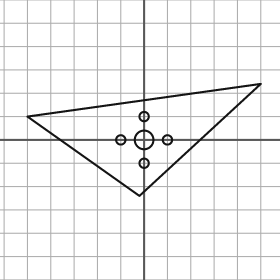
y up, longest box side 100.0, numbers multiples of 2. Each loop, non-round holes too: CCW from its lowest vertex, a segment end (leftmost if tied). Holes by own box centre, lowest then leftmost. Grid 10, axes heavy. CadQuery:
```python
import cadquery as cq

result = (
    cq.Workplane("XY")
    .moveTo(-2.0, -24.0)
    .lineTo(50.0, 24.0)
    .lineTo(-50.0, 10.0)
    .close()
    .moveTo(0.0, -10.0)
    .circle(2.0)
    .moveTo(-10.0, 0.0)
    .circle(2.0)
    .moveTo(0.0, 0.0)
    .circle(4.0)
    .moveTo(10.0, 0.0)
    .circle(2.0)
    .moveTo(0.0, 10.0)
    .circle(2.0)
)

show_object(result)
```